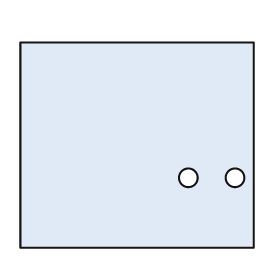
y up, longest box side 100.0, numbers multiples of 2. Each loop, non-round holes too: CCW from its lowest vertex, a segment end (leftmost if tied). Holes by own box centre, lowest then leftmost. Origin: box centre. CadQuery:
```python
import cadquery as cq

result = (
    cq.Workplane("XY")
    .moveTo(-50.0, -44.0)
    .lineTo(50.0, -44.0)
    .lineTo(50.0, 44.0)
    .lineTo(-50.0, 44.0)
    .close()
    .moveTo(22.0, -14.0)
    .circle(4.0)
    .moveTo(42.0, -14.0)
    .circle(4.0)
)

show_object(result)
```